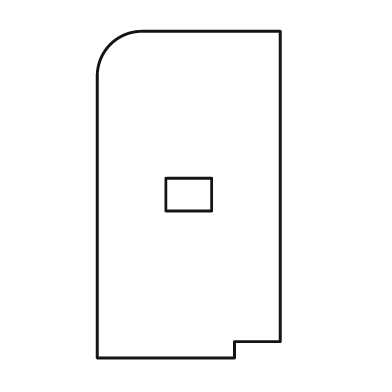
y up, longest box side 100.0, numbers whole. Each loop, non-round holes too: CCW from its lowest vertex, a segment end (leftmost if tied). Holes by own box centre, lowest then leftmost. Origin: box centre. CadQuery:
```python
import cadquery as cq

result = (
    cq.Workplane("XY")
    .moveTo(-28.0, -50.0)
    .lineTo(14.0, -50.0)
    .lineTo(14.0, -45.0)
    .lineTo(28.0, -45.0)
    .lineTo(28.0, 50.0)
    .lineTo(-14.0, 50.0)
    .threePointArc((-24.0, 46.0), (-28.0, 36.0))
    .close()
    .moveTo(-7.0, -5.0)
    .lineTo(7.0, -5.0)
    .lineTo(7.0, 5.0)
    .lineTo(-7.0, 5.0)
    .close()
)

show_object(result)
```